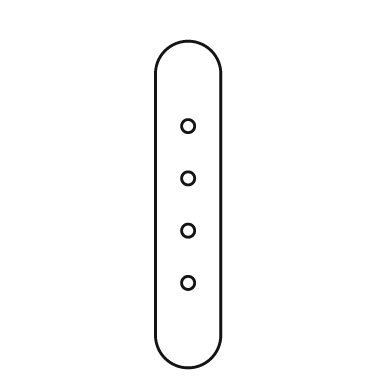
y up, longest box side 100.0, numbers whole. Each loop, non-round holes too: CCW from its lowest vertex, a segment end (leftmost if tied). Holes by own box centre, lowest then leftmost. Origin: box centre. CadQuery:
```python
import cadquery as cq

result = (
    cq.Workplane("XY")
    .moveTo(-10.0, -40.0)
    .threePointArc((0.0, -50.0), (10.0, -40.0))
    .lineTo(10.0, 40.0)
    .threePointArc((0.0, 50.0), (-10.0, 40.0))
    .close()
    .moveTo(0.0, -24.0)
    .circle(2.0)
    .moveTo(0.0, -8.0)
    .circle(2.0)
    .moveTo(0.0, 8.0)
    .circle(2.0)
    .moveTo(0.0, 24.0)
    .circle(2.0)
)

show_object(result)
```